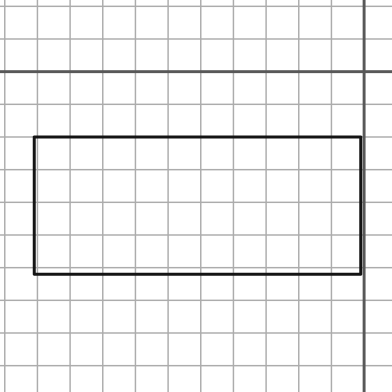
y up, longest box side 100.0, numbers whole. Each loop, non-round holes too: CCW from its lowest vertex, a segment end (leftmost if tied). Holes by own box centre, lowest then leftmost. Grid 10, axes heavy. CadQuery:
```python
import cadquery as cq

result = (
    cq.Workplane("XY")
    .moveTo(-101.0, -62.0)
    .lineTo(-1.0, -62.0)
    .lineTo(-1.0, -20.0)
    .lineTo(-101.0, -20.0)
    .close()
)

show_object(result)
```